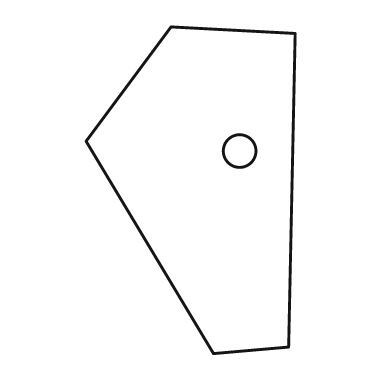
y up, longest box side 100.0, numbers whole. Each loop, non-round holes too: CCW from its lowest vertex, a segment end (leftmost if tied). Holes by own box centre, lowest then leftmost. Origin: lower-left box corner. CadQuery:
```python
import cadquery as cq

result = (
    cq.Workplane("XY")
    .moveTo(39.0, 0.0)
    .lineTo(62.0, 2.0)
    .lineTo(64.0, 98.0)
    .lineTo(26.0, 100.0)
    .lineTo(0.0, 65.0)
    .close()
    .moveTo(47.0, 62.0)
    .circle(5.0)
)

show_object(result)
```